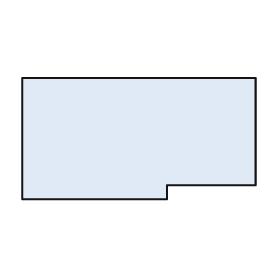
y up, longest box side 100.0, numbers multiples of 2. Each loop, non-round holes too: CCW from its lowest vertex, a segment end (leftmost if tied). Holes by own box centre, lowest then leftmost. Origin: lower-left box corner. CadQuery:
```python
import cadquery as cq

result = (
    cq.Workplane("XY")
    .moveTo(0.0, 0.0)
    .lineTo(62.0, 0.0)
    .lineTo(62.0, 6.0)
    .lineTo(100.0, 6.0)
    .lineTo(100.0, 52.0)
    .lineTo(0.0, 52.0)
    .close()
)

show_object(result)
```